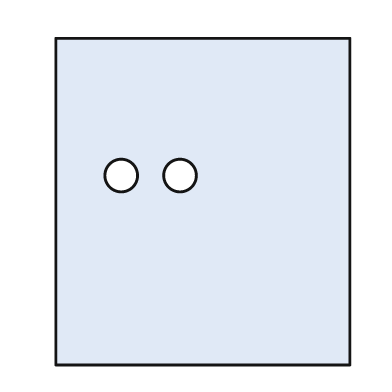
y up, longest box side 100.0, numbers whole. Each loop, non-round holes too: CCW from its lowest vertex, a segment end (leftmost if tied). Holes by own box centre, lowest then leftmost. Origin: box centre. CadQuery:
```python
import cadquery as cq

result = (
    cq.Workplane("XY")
    .moveTo(-45.0, -50.0)
    .lineTo(45.0, -50.0)
    .lineTo(45.0, 50.0)
    .lineTo(-45.0, 50.0)
    .close()
    .moveTo(-25.0, 8.0)
    .circle(5.0)
    .moveTo(-7.0, 8.0)
    .circle(5.0)
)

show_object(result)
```